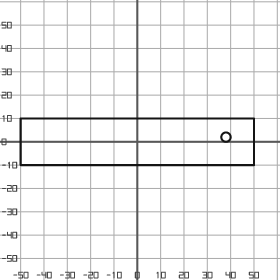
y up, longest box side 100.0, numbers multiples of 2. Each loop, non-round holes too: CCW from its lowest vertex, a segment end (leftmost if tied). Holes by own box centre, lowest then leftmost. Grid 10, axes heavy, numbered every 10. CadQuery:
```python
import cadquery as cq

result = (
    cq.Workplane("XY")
    .moveTo(-50.0, -10.0)
    .lineTo(50.0, -10.0)
    .lineTo(50.0, 10.0)
    .lineTo(-50.0, 10.0)
    .close()
    .moveTo(38.0, 2.0)
    .circle(2.0)
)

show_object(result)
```